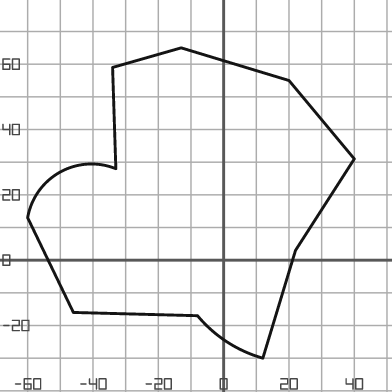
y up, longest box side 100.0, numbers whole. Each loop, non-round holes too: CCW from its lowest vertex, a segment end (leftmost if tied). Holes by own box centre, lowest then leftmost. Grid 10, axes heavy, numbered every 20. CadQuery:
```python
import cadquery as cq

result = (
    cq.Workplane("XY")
    .moveTo(12.0, -30.0)
    .lineTo(22.0, 3.0)
    .lineTo(40.0, 31.0)
    .lineTo(20.0, 55.0)
    .lineTo(-13.0, 65.0)
    .lineTo(-34.0, 59.0)
    .lineTo(-33.0, 28.0)
    .threePointArc((-50.0, 27.0), (-60.0, 13.0))
    .lineTo(-46.0, -16.0)
    .lineTo(-8.0, -17.0)
    .threePointArc((1.0, -25.0), (12.0, -30.0))
    .close()
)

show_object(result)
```